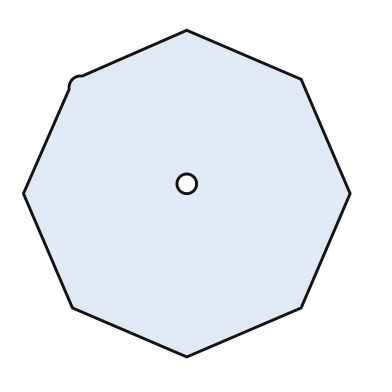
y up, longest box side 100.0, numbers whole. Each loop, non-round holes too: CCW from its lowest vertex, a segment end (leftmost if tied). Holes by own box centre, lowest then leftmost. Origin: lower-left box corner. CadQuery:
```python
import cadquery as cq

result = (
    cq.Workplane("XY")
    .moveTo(50.0, 0.0)
    .lineTo(85.0, 15.0)
    .lineTo(100.0, 50.0)
    .lineTo(85.0, 85.0)
    .lineTo(50.0, 100.0)
    .lineTo(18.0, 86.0)
    .threePointArc((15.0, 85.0), (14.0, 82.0))
    .lineTo(0.0, 50.0)
    .lineTo(15.0, 15.0)
    .close()
    .moveTo(50.0, 53.0)
    .circle(3.0)
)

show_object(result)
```